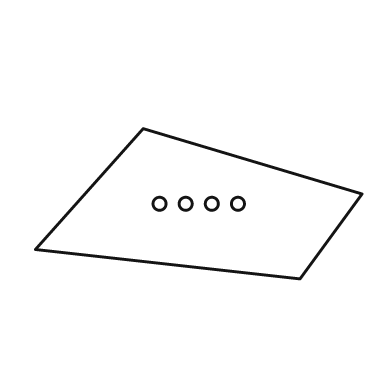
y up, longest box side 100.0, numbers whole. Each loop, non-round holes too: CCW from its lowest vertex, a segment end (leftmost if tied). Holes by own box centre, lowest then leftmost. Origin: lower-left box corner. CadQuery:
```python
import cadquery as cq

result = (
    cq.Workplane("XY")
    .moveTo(81.0, 0.0)
    .lineTo(100.0, 26.0)
    .lineTo(33.0, 46.0)
    .lineTo(0.0, 9.0)
    .close()
    .moveTo(38.0, 23.0)
    .circle(2.0)
    .moveTo(46.0, 23.0)
    .circle(2.0)
    .moveTo(54.0, 23.0)
    .circle(2.0)
    .moveTo(62.0, 23.0)
    .circle(2.0)
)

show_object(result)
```